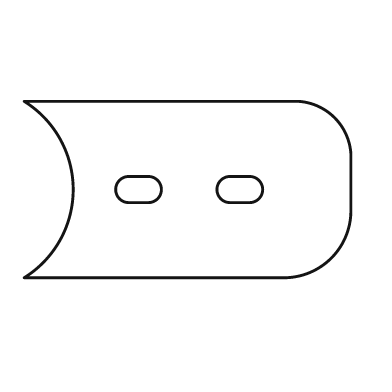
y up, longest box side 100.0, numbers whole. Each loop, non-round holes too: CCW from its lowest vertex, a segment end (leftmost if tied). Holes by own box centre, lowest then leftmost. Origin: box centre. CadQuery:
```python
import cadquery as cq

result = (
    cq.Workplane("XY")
    .moveTo(-50.0, -27.0)
    .lineTo(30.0, -27.0)
    .threePointArc((44.0, -21.0), (50.0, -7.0))
    .lineTo(50.0, 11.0)
    .threePointArc((45.0, 22.0), (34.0, 27.0))
    .lineTo(-50.0, 27.0)
    .threePointArc((-35.0, 0.0), (-50.0, -27.0))
    .close()
    .moveTo(-18.0, -4.0)
    .lineTo(-12.0, -4.0)
    .threePointArc((-8.0, 0.0), (-12.0, 4.0))
    .lineTo(-18.0, 4.0)
    .threePointArc((-22.0, 0.0), (-18.0, -4.0))
    .close()
    .moveTo(13.0, -4.0)
    .lineTo(19.0, -4.0)
    .threePointArc((23.0, 0.0), (19.0, 4.0))
    .lineTo(13.0, 4.0)
    .threePointArc((9.0, 0.0), (13.0, -4.0))
    .close()
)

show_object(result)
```